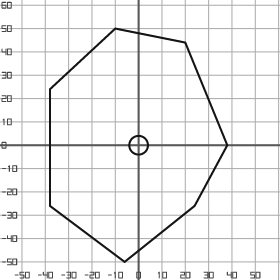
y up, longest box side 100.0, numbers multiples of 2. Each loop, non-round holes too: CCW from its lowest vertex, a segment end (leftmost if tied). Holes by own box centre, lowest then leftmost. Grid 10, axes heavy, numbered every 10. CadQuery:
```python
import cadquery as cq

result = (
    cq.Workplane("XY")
    .moveTo(-6.0, -50.0)
    .lineTo(24.0, -26.0)
    .lineTo(38.0, 0.0)
    .lineTo(20.0, 44.0)
    .lineTo(-10.0, 50.0)
    .lineTo(-38.0, 24.0)
    .lineTo(-38.0, -26.0)
    .close()
    .moveTo(0.0, 0.0)
    .circle(4.0)
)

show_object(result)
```